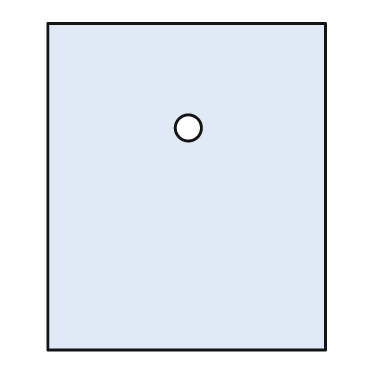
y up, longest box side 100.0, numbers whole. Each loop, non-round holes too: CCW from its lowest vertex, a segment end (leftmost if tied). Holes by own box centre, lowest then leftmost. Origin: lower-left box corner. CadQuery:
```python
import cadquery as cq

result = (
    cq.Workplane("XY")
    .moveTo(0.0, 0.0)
    .lineTo(85.0, 0.0)
    .lineTo(85.0, 100.0)
    .lineTo(0.0, 100.0)
    .close()
    .moveTo(43.0, 68.0)
    .circle(4.0)
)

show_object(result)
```